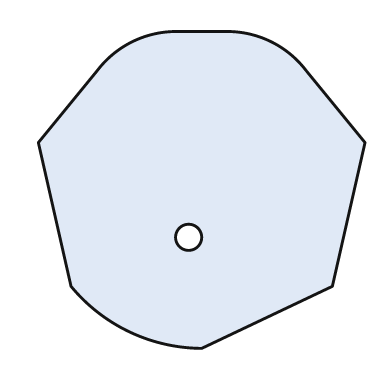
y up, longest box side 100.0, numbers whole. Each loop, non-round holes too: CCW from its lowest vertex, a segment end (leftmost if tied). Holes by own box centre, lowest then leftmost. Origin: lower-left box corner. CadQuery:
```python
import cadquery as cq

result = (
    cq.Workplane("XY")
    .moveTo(50.0, 0.0)
    .lineTo(90.0, 19.0)
    .lineTo(100.0, 63.0)
    .lineTo(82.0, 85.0)
    .threePointArc((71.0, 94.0), (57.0, 97.0))
    .lineTo(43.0, 97.0)
    .threePointArc((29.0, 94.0), (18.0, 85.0))
    .lineTo(0.0, 63.0)
    .lineTo(10.0, 19.0)
    .threePointArc((28.0, 5.0), (50.0, 0.0))
    .close()
    .moveTo(46.0, 34.0)
    .circle(4.0)
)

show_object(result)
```